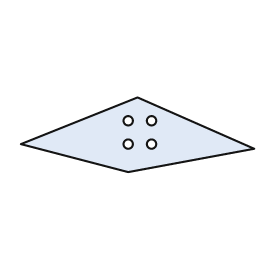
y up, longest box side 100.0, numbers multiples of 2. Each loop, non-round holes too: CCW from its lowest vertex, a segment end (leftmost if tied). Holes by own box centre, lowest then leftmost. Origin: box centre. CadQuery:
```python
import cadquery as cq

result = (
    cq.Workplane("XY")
    .moveTo(-4.0, -16.0)
    .lineTo(50.0, -6.0)
    .lineTo(0.0, 16.0)
    .lineTo(-50.0, -4.0)
    .close()
    .moveTo(-4.0, -4.0)
    .circle(2.0)
    .moveTo(6.0, -4.0)
    .circle(2.0)
    .moveTo(-4.0, 6.0)
    .circle(2.0)
    .moveTo(6.0, 6.0)
    .circle(2.0)
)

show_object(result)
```